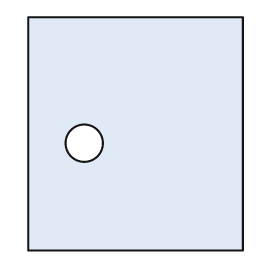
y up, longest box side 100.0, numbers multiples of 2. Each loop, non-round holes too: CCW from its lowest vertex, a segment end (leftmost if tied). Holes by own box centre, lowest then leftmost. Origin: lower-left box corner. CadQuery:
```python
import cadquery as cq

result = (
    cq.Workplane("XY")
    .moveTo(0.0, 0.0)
    .lineTo(92.0, 0.0)
    .lineTo(92.0, 100.0)
    .lineTo(0.0, 100.0)
    .close()
    .moveTo(24.0, 46.0)
    .circle(8.0)
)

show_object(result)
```